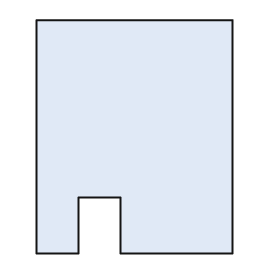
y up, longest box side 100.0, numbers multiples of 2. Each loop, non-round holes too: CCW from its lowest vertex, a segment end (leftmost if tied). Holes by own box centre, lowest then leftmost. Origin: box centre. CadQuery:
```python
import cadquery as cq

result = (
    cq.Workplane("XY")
    .moveTo(-42.0, -50.0)
    .lineTo(-24.0, -50.0)
    .lineTo(-24.0, -26.0)
    .lineTo(-6.0, -26.0)
    .lineTo(-6.0, -50.0)
    .lineTo(42.0, -50.0)
    .lineTo(42.0, 50.0)
    .lineTo(-42.0, 50.0)
    .close()
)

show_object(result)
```